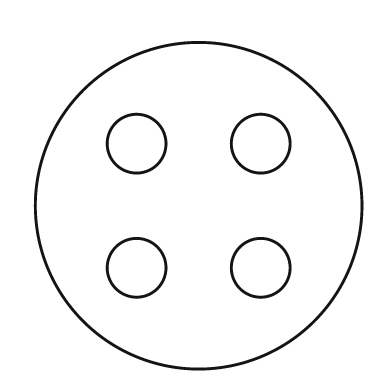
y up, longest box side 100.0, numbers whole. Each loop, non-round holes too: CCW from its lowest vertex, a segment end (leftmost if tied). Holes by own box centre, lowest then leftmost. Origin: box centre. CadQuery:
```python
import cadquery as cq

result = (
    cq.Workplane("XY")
    .moveTo(0.0, 0.0)
    .circle(50.0)
    .moveTo(-19.0, -19.0)
    .circle(9.0)
    .moveTo(19.0, -19.0)
    .circle(9.0)
    .moveTo(-19.0, 19.0)
    .circle(9.0)
    .moveTo(19.0, 19.0)
    .circle(9.0)
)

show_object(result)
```